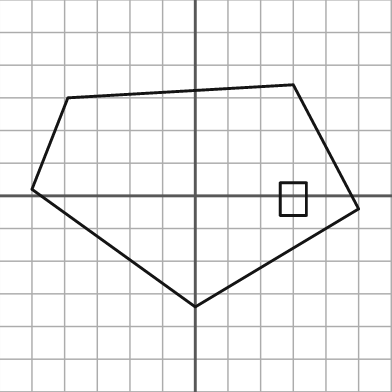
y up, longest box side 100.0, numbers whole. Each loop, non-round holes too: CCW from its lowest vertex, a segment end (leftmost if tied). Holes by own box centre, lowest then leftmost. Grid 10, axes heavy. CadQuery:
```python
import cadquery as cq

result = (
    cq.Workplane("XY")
    .moveTo(0.0, -34.0)
    .lineTo(50.0, -4.0)
    .lineTo(30.0, 34.0)
    .lineTo(-39.0, 30.0)
    .lineTo(-50.0, 2.0)
    .close()
    .moveTo(26.0, -6.0)
    .lineTo(34.0, -6.0)
    .lineTo(34.0, 4.0)
    .lineTo(26.0, 4.0)
    .close()
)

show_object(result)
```